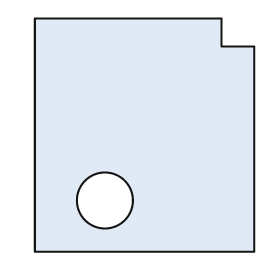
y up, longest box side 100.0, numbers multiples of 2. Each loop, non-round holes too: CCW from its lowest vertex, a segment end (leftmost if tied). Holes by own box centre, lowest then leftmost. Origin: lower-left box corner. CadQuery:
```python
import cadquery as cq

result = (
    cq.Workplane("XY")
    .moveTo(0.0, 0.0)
    .lineTo(94.0, 0.0)
    .lineTo(94.0, 88.0)
    .lineTo(80.0, 88.0)
    .lineTo(80.0, 100.0)
    .lineTo(0.0, 100.0)
    .close()
    .moveTo(30.0, 22.0)
    .circle(12.0)
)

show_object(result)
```